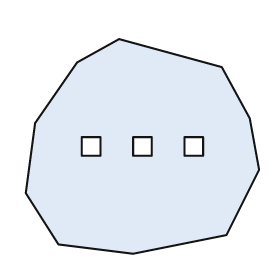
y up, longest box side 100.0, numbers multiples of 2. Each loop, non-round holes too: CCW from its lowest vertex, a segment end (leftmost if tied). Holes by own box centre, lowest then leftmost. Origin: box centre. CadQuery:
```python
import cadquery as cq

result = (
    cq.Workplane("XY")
    .moveTo(-4.0, -46.0)
    .lineTo(36.0, -38.0)
    .lineTo(50.0, -10.0)
    .lineTo(46.0, 12.0)
    .lineTo(34.0, 34.0)
    .lineTo(-10.0, 46.0)
    .lineTo(-28.0, 36.0)
    .lineTo(-46.0, 10.0)
    .lineTo(-50.0, -20.0)
    .lineTo(-36.0, -42.0)
    .close()
    .moveTo(-26.0, -4.0)
    .lineTo(-18.0, -4.0)
    .lineTo(-18.0, 4.0)
    .lineTo(-26.0, 4.0)
    .close()
    .moveTo(-4.0, -4.0)
    .lineTo(4.0, -4.0)
    .lineTo(4.0, 4.0)
    .lineTo(-4.0, 4.0)
    .close()
    .moveTo(18.0, -4.0)
    .lineTo(26.0, -4.0)
    .lineTo(26.0, 4.0)
    .lineTo(18.0, 4.0)
    .close()
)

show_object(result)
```